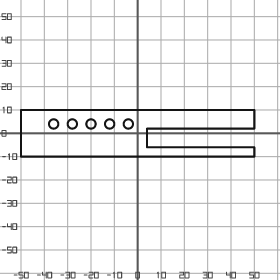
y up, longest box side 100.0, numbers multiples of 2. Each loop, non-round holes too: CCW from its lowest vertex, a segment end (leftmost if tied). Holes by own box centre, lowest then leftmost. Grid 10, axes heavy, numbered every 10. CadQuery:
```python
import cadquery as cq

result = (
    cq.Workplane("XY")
    .moveTo(-50.0, -10.0)
    .lineTo(50.0, -10.0)
    .lineTo(50.0, -6.0)
    .lineTo(4.0, -6.0)
    .lineTo(4.0, 2.0)
    .lineTo(50.0, 2.0)
    .lineTo(50.0, 10.0)
    .lineTo(-50.0, 10.0)
    .close()
    .moveTo(-36.0, 4.0)
    .circle(2.0)
    .moveTo(-28.0, 4.0)
    .circle(2.0)
    .moveTo(-20.0, 4.0)
    .circle(2.0)
    .moveTo(-12.0, 4.0)
    .circle(2.0)
    .moveTo(-4.0, 4.0)
    .circle(2.0)
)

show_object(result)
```